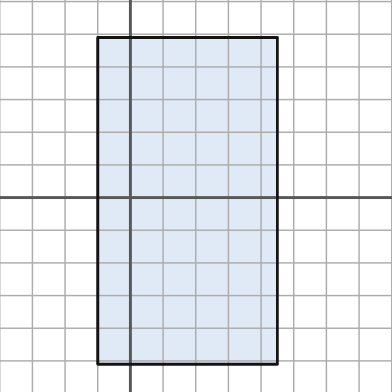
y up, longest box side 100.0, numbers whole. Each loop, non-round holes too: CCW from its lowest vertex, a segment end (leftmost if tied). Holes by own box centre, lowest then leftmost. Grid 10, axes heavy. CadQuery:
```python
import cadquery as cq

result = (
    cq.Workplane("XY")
    .moveTo(-10.0, -51.0)
    .lineTo(45.0, -51.0)
    .lineTo(45.0, 49.0)
    .lineTo(-10.0, 49.0)
    .close()
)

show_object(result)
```